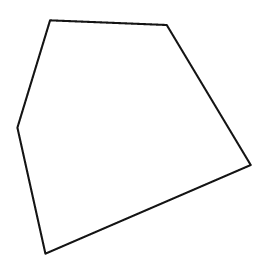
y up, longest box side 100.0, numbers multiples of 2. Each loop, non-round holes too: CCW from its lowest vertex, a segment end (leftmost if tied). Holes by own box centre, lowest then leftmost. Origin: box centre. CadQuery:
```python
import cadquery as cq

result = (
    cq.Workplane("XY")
    .moveTo(-38.0, -50.0)
    .lineTo(50.0, -12.0)
    .lineTo(14.0, 48.0)
    .lineTo(-36.0, 50.0)
    .lineTo(-50.0, 4.0)
    .close()
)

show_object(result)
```